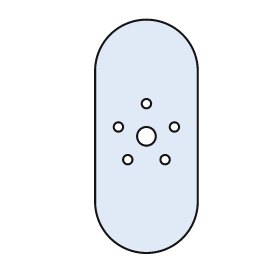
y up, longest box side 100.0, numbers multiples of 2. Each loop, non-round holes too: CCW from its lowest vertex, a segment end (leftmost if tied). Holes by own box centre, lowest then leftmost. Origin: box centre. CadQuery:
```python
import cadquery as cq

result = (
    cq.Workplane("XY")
    .moveTo(-22.0, -28.0)
    .threePointArc((0.0, -50.0), (22.0, -28.0))
    .lineTo(22.0, 28.0)
    .threePointArc((0.0, 50.0), (-22.0, 28.0))
    .close()
    .moveTo(-8.0, -10.0)
    .circle(2.0)
    .moveTo(8.0, -10.0)
    .circle(2.0)
    .moveTo(0.0, 0.0)
    .circle(4.0)
    .moveTo(-12.0, 4.0)
    .circle(2.0)
    .moveTo(12.0, 4.0)
    .circle(2.0)
    .moveTo(0.0, 14.0)
    .circle(2.0)
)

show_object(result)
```